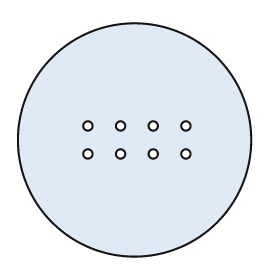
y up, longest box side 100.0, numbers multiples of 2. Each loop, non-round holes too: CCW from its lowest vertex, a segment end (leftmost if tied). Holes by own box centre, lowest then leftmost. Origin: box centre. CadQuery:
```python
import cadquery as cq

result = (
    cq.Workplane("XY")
    .moveTo(0.0, 0.0)
    .circle(50.0)
    .moveTo(-20.0, -6.0)
    .circle(2.0)
    .moveTo(-6.0, -6.0)
    .circle(2.0)
    .moveTo(8.0, -6.0)
    .circle(2.0)
    .moveTo(22.0, -6.0)
    .circle(2.0)
    .moveTo(-20.0, 6.0)
    .circle(2.0)
    .moveTo(-6.0, 6.0)
    .circle(2.0)
    .moveTo(8.0, 6.0)
    .circle(2.0)
    .moveTo(22.0, 6.0)
    .circle(2.0)
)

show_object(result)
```